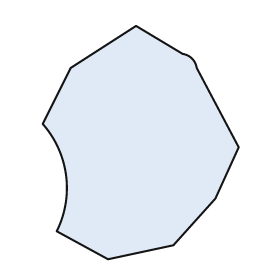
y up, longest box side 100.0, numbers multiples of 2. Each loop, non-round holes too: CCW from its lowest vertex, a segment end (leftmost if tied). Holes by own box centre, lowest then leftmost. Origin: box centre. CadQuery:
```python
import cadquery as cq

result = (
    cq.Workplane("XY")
    .moveTo(-14.0, -50.0)
    .lineTo(14.0, -44.0)
    .lineTo(32.0, -24.0)
    .lineTo(42.0, -2.0)
    .lineTo(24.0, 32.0)
    .threePointArc((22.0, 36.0), (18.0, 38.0))
    .lineTo(-2.0, 50.0)
    .lineTo(-30.0, 32.0)
    .lineTo(-42.0, 8.0)
    .threePointArc((-32.0, -14.0), (-36.0, -38.0))
    .close()
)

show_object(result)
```